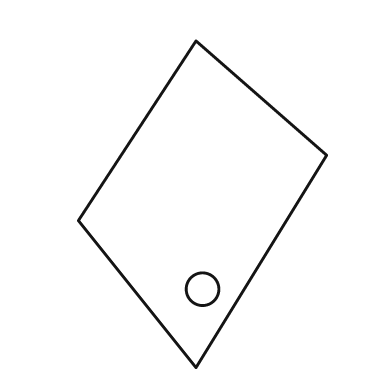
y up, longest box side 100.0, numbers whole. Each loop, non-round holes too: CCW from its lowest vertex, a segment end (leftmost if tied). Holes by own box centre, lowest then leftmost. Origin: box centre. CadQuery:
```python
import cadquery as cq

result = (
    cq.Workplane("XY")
    .moveTo(-2.0, -50.0)
    .lineTo(38.0, 15.0)
    .lineTo(-2.0, 50.0)
    .lineTo(-38.0, -5.0)
    .close()
    .moveTo(0.0, -26.0)
    .circle(5.0)
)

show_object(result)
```